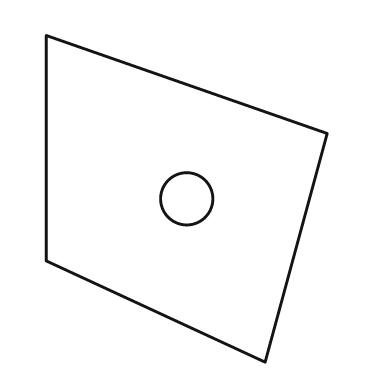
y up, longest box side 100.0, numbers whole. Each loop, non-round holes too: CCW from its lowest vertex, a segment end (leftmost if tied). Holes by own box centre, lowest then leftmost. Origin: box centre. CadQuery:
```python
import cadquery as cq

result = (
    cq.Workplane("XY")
    .moveTo(24.0, -50.0)
    .lineTo(43.0, 20.0)
    .lineTo(-43.0, 50.0)
    .lineTo(-43.0, -19.0)
    .close()
    .moveTo(0.0, 0.0)
    .circle(8.0)
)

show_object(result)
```